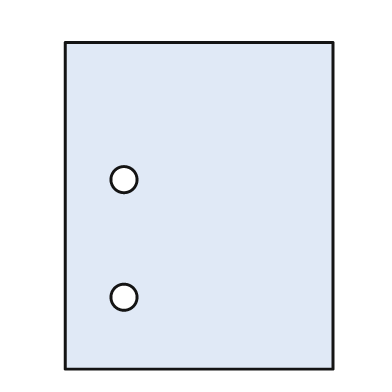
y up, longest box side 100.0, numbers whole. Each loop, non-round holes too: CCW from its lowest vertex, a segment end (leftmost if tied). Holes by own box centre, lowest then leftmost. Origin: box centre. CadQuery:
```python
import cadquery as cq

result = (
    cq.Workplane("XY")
    .moveTo(-41.0, -50.0)
    .lineTo(41.0, -50.0)
    .lineTo(41.0, 50.0)
    .lineTo(-41.0, 50.0)
    .close()
    .moveTo(-23.0, -28.0)
    .circle(4.0)
    .moveTo(-23.0, 8.0)
    .circle(4.0)
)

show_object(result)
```